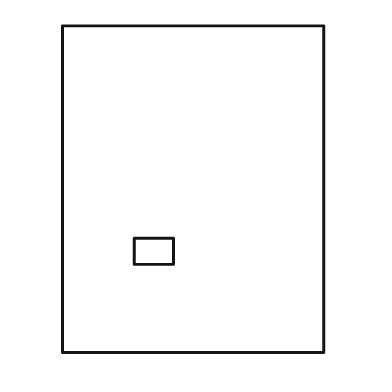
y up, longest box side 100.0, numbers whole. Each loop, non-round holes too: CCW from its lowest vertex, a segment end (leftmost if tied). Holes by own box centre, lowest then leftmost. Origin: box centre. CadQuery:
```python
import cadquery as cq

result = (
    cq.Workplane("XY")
    .moveTo(-40.0, -50.0)
    .lineTo(40.0, -50.0)
    .lineTo(40.0, 50.0)
    .lineTo(-40.0, 50.0)
    .close()
    .moveTo(-18.0, -23.0)
    .lineTo(-6.0, -23.0)
    .lineTo(-6.0, -15.0)
    .lineTo(-18.0, -15.0)
    .close()
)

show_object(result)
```